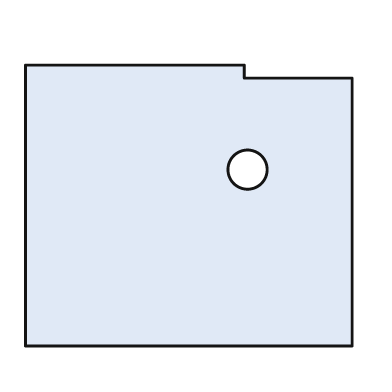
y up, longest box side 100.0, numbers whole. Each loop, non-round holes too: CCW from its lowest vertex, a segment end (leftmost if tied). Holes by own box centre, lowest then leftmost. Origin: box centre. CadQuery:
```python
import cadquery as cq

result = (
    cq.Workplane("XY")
    .moveTo(-50.0, -43.0)
    .lineTo(50.0, -43.0)
    .lineTo(50.0, 39.0)
    .lineTo(17.0, 39.0)
    .lineTo(17.0, 43.0)
    .lineTo(-50.0, 43.0)
    .close()
    .moveTo(18.0, 11.0)
    .circle(6.0)
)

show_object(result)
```